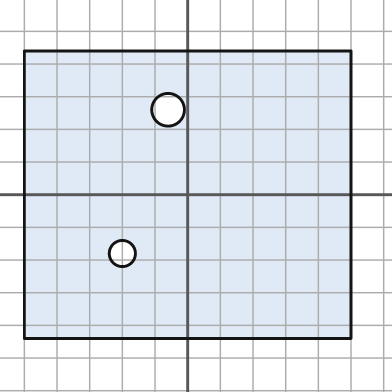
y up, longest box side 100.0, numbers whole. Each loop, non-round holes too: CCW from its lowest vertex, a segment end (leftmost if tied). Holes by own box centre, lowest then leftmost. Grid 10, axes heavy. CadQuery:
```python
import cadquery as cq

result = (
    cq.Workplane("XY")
    .moveTo(-50.0, -44.0)
    .lineTo(50.0, -44.0)
    .lineTo(50.0, 44.0)
    .lineTo(-50.0, 44.0)
    .close()
    .moveTo(-20.0, -18.0)
    .circle(4.0)
    .moveTo(-6.0, 26.0)
    .circle(5.0)
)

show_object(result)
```